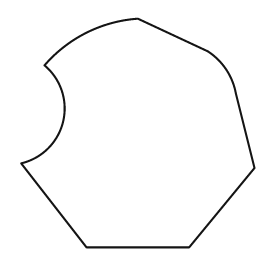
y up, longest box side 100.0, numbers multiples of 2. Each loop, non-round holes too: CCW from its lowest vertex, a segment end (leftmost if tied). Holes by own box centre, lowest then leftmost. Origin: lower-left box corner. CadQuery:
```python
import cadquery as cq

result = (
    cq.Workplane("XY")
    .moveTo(28.0, 0.0)
    .lineTo(72.0, 0.0)
    .lineTo(100.0, 34.0)
    .lineTo(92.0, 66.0)
    .threePointArc((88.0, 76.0), (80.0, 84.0))
    .lineTo(50.0, 98.0)
    .threePointArc((28.0, 92.0), (10.0, 78.0))
    .threePointArc((18.0, 54.0), (0.0, 36.0))
    .close()
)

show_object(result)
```